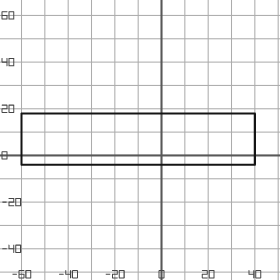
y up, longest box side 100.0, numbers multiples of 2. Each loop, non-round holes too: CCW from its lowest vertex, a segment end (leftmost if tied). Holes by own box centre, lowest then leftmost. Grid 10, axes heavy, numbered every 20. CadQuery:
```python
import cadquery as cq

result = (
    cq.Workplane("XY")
    .moveTo(-60.0, -4.0)
    .lineTo(40.0, -4.0)
    .lineTo(40.0, 18.0)
    .lineTo(-60.0, 18.0)
    .close()
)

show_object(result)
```